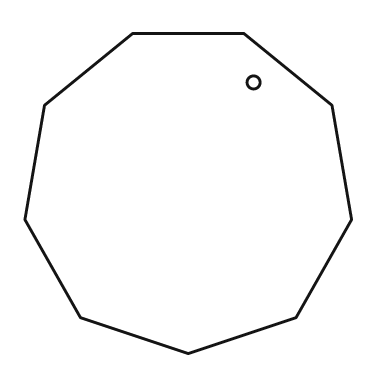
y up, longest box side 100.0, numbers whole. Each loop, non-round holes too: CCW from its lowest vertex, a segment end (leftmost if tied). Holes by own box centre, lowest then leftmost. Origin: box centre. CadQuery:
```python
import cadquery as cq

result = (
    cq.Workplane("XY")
    .moveTo(0.0, -49.0)
    .lineTo(33.0, -38.0)
    .lineTo(50.0, -8.0)
    .lineTo(44.0, 27.0)
    .lineTo(17.0, 49.0)
    .lineTo(-17.0, 49.0)
    .lineTo(-44.0, 27.0)
    .lineTo(-50.0, -8.0)
    .lineTo(-33.0, -38.0)
    .close()
    .moveTo(20.0, 34.0)
    .circle(2.0)
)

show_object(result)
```